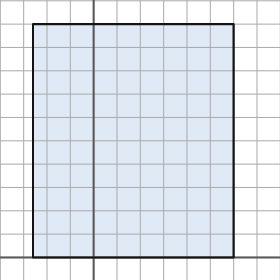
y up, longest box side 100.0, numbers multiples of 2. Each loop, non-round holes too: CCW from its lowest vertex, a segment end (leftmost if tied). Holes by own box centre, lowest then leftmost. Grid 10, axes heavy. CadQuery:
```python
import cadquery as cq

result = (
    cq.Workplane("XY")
    .moveTo(-26.0, 0.0)
    .lineTo(60.0, 0.0)
    .lineTo(60.0, 100.0)
    .lineTo(-26.0, 100.0)
    .close()
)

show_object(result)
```